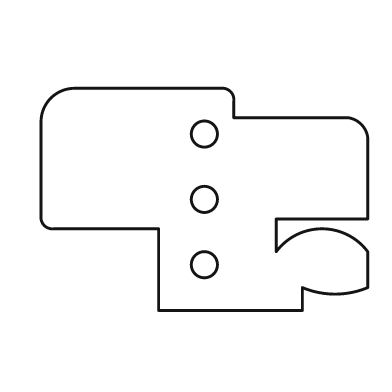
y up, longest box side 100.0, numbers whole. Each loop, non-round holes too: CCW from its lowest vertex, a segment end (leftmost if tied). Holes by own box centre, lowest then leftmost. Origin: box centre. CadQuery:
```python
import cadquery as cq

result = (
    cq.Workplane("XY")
    .moveTo(-14.0, -34.0)
    .lineTo(30.0, -34.0)
    .lineTo(30.0, -27.0)
    .threePointArc((40.0, -29.0), (50.0, -27.0))
    .lineTo(50.0, -16.0)
    .threePointArc((36.0, -9.0), (22.0, -16.0))
    .lineTo(22.0, -6.0)
    .lineTo(50.0, -6.0)
    .lineTo(50.0, 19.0)
    .threePointArc((48.0, 23.0), (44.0, 25.0))
    .lineTo(9.0, 25.0)
    .lineTo(9.0, 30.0)
    .threePointArc((8.0, 33.0), (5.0, 34.0))
    .lineTo(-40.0, 34.0)
    .threePointArc((-47.0, 31.0), (-50.0, 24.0))
    .lineTo(-50.0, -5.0)
    .threePointArc((-49.0, -8.0), (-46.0, -9.0))
    .lineTo(-14.0, -9.0)
    .close()
    .moveTo(0.0, -20.0)
    .circle(4.0)
    .moveTo(0.0, 0.0)
    .circle(4.0)
    .moveTo(0.0, 20.0)
    .circle(4.0)
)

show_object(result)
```